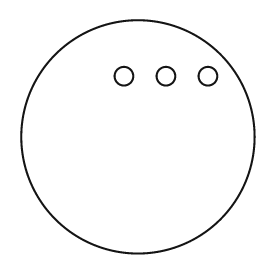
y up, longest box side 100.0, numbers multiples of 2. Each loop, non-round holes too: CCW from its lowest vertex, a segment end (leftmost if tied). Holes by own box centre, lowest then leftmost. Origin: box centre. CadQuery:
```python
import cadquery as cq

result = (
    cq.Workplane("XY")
    .moveTo(0.0, 0.0)
    .circle(50.0)
    .moveTo(-6.0, 26.0)
    .circle(4.0)
    .moveTo(12.0, 26.0)
    .circle(4.0)
    .moveTo(30.0, 26.0)
    .circle(4.0)
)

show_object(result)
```